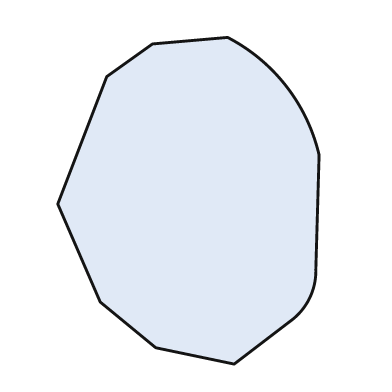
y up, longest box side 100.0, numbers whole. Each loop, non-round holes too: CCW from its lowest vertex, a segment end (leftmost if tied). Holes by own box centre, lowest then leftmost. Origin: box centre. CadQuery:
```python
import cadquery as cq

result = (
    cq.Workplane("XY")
    .moveTo(14.0, -50.0)
    .lineTo(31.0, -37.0)
    .threePointArc((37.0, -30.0), (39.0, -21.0))
    .lineTo(40.0, 14.0)
    .threePointArc((30.0, 35.0), (12.0, 50.0))
    .lineTo(-11.0, 48.0)
    .lineTo(-25.0, 38.0)
    .lineTo(-40.0, -1.0)
    .lineTo(-27.0, -31.0)
    .lineTo(-10.0, -45.0)
    .close()
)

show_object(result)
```